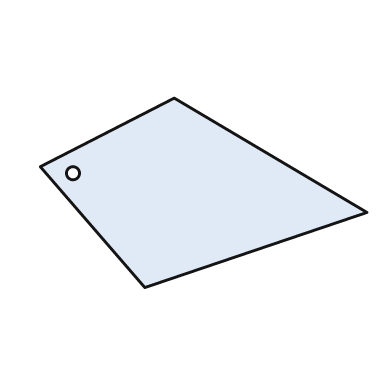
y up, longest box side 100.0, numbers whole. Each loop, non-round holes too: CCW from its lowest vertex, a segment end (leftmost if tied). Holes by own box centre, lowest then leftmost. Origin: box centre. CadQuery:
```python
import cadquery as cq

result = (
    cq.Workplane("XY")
    .moveTo(-18.0, -29.0)
    .lineTo(50.0, -6.0)
    .lineTo(-9.0, 29.0)
    .lineTo(-50.0, 8.0)
    .close()
    .moveTo(-40.0, 6.0)
    .circle(2.0)
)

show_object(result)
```